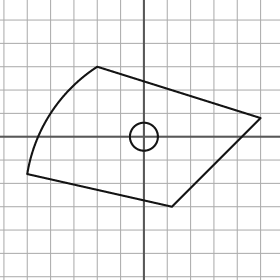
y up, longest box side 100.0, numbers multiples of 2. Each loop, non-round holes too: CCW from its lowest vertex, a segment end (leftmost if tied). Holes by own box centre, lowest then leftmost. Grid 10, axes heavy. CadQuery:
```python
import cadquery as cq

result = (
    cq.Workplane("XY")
    .moveTo(12.0, -30.0)
    .lineTo(50.0, 8.0)
    .lineTo(-20.0, 30.0)
    .threePointArc((-40.0, 10.0), (-50.0, -16.0))
    .close()
    .moveTo(0.0, 0.0)
    .circle(6.0)
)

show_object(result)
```